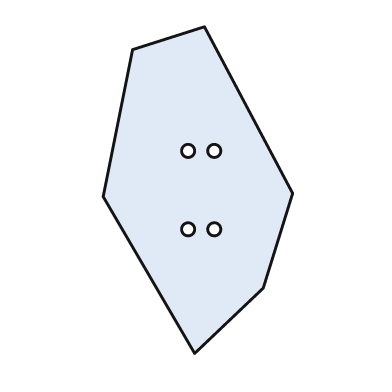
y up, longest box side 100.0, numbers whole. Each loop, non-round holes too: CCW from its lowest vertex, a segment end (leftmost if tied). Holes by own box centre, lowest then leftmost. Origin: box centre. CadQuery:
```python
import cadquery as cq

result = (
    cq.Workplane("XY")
    .moveTo(-1.0, -50.0)
    .lineTo(20.0, -30.0)
    .lineTo(29.0, -1.0)
    .lineTo(2.0, 50.0)
    .lineTo(-20.0, 43.0)
    .lineTo(-29.0, -2.0)
    .close()
    .moveTo(-3.0, -12.0)
    .circle(2.0)
    .moveTo(5.0, -12.0)
    .circle(2.0)
    .moveTo(-3.0, 12.0)
    .circle(2.0)
    .moveTo(5.0, 12.0)
    .circle(2.0)
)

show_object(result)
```